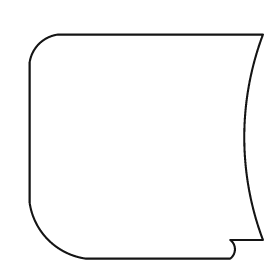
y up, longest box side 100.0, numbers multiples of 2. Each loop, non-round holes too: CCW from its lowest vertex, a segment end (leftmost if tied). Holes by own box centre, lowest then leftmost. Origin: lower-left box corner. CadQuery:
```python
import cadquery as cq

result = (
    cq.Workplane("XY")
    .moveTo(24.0, 0.0)
    .lineTo(86.0, 0.0)
    .threePointArc((88.0, 4.0), (86.0, 8.0))
    .lineTo(100.0, 8.0)
    .threePointArc((92.0, 52.0), (100.0, 96.0))
    .lineTo(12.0, 96.0)
    .threePointArc((4.0, 92.0), (0.0, 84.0))
    .lineTo(0.0, 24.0)
    .threePointArc((8.0, 8.0), (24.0, 0.0))
    .close()
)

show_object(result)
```